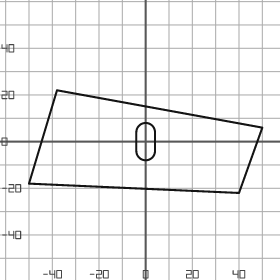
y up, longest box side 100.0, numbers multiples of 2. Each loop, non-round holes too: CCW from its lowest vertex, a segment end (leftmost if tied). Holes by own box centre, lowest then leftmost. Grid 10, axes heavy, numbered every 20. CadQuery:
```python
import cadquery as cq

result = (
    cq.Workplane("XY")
    .moveTo(40.0, -22.0)
    .lineTo(50.0, 6.0)
    .lineTo(-38.0, 22.0)
    .lineTo(-50.0, -18.0)
    .close()
    .moveTo(-4.0, -4.0)
    .threePointArc((0.0, -8.0), (4.0, -4.0))
    .lineTo(4.0, 4.0)
    .threePointArc((0.0, 8.0), (-4.0, 4.0))
    .close()
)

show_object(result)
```